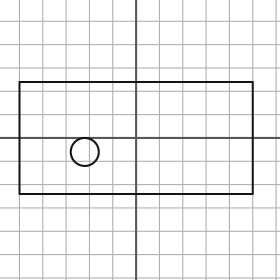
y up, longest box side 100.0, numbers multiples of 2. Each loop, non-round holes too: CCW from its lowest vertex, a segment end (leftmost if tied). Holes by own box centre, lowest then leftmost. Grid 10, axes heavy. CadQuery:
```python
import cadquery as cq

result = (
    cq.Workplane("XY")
    .moveTo(-50.0, -24.0)
    .lineTo(50.0, -24.0)
    .lineTo(50.0, 24.0)
    .lineTo(-50.0, 24.0)
    .close()
    .moveTo(-22.0, -6.0)
    .circle(6.0)
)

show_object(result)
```